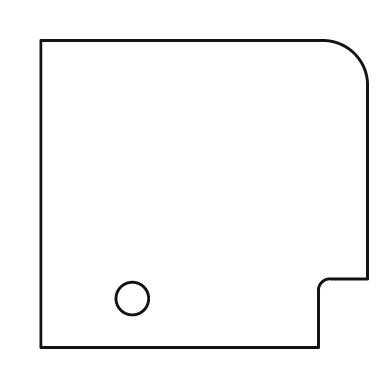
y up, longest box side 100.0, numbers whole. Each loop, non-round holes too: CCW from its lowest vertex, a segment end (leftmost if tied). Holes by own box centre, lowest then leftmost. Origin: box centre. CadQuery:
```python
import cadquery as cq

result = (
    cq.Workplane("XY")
    .moveTo(-50.0, -47.0)
    .lineTo(35.0, -47.0)
    .lineTo(35.0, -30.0)
    .threePointArc((36.0, -27.0), (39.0, -26.0))
    .lineTo(50.0, -26.0)
    .lineTo(50.0, 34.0)
    .threePointArc((46.0, 43.0), (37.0, 47.0))
    .lineTo(-50.0, 47.0)
    .close()
    .moveTo(-22.0, -32.0)
    .circle(5.0)
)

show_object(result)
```